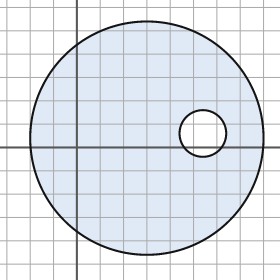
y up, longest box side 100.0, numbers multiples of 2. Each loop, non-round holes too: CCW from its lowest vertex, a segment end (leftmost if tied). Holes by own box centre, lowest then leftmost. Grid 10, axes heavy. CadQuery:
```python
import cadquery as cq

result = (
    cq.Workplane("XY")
    .moveTo(30.0, 4.0)
    .circle(50.0)
    .moveTo(54.0, 6.0)
    .circle(10.0)
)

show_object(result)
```